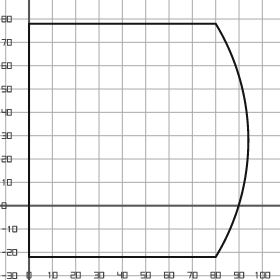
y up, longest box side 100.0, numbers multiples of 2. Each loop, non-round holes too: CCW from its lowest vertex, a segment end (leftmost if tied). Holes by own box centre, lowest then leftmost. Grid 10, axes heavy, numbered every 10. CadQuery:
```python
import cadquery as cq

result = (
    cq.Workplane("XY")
    .moveTo(0.0, -22.0)
    .lineTo(80.0, -22.0)
    .threePointArc((94.0, 28.0), (80.0, 78.0))
    .lineTo(0.0, 78.0)
    .close()
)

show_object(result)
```